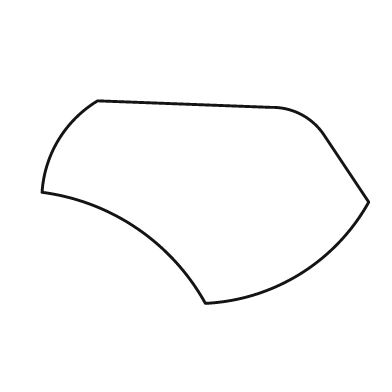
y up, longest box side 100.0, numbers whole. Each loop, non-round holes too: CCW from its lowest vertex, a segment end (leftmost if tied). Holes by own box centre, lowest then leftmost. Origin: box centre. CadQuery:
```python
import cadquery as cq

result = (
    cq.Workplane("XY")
    .moveTo(0.0, -31.0)
    .threePointArc((29.0, -22.0), (50.0, 0.0))
    .lineTo(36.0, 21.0)
    .threePointArc((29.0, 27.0), (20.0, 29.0))
    .lineTo(-33.0, 31.0)
    .threePointArc((-45.0, 19.0), (-50.0, 3.0))
    .threePointArc((-21.0, -8.0), (0.0, -31.0))
    .close()
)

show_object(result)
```